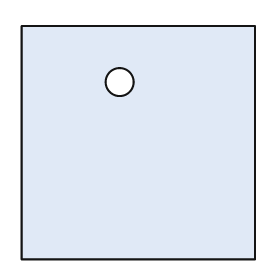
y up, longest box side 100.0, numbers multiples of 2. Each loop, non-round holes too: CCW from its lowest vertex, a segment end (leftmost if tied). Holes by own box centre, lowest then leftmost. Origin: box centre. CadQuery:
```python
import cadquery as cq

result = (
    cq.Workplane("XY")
    .moveTo(-50.0, -50.0)
    .lineTo(50.0, -50.0)
    .lineTo(50.0, 50.0)
    .lineTo(-50.0, 50.0)
    .close()
    .moveTo(-8.0, 26.0)
    .circle(6.0)
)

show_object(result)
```